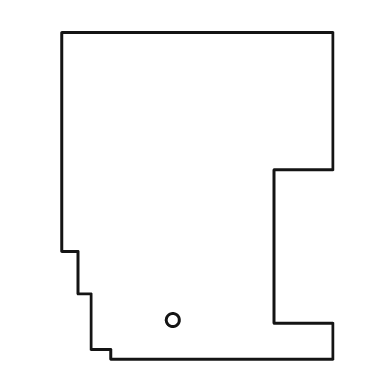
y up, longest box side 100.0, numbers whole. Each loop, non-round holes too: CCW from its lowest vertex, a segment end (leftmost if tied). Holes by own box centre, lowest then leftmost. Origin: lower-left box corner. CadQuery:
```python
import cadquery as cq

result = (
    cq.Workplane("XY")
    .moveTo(15.0, 0.0)
    .lineTo(83.0, 0.0)
    .lineTo(83.0, 11.0)
    .lineTo(65.0, 11.0)
    .lineTo(65.0, 58.0)
    .lineTo(83.0, 58.0)
    .lineTo(83.0, 100.0)
    .lineTo(0.0, 100.0)
    .lineTo(0.0, 33.0)
    .lineTo(5.0, 33.0)
    .lineTo(5.0, 20.0)
    .lineTo(9.0, 20.0)
    .lineTo(9.0, 3.0)
    .lineTo(15.0, 3.0)
    .close()
    .moveTo(34.0, 12.0)
    .circle(2.0)
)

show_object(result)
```